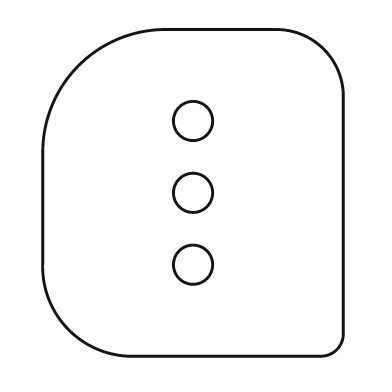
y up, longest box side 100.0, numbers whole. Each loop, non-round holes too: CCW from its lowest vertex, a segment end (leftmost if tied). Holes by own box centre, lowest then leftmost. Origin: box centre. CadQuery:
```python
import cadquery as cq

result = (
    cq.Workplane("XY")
    .moveTo(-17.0, -50.0)
    .lineTo(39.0, -50.0)
    .threePointArc((44.0, -48.0), (46.0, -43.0))
    .lineTo(46.0, 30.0)
    .threePointArc((40.0, 44.0), (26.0, 50.0))
    .lineTo(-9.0, 50.0)
    .threePointArc((-35.0, 39.0), (-46.0, 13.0))
    .lineTo(-46.0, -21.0)
    .threePointArc((-38.0, -42.0), (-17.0, -50.0))
    .close()
    .moveTo(0.0, -22.0)
    .circle(6.0)
    .moveTo(0.0, 0.0)
    .circle(6.0)
    .moveTo(0.0, 22.0)
    .circle(6.0)
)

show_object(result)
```